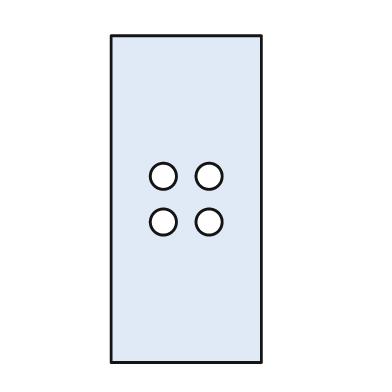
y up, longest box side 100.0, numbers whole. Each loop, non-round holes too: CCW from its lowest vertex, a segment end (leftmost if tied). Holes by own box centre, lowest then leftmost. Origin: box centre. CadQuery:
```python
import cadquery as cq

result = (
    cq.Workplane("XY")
    .moveTo(-23.0, -50.0)
    .lineTo(23.0, -50.0)
    .lineTo(23.0, 50.0)
    .lineTo(-23.0, 50.0)
    .close()
    .moveTo(-7.0, -7.0)
    .circle(4.0)
    .moveTo(7.0, -7.0)
    .circle(4.0)
    .moveTo(-7.0, 7.0)
    .circle(4.0)
    .moveTo(7.0, 7.0)
    .circle(4.0)
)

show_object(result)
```